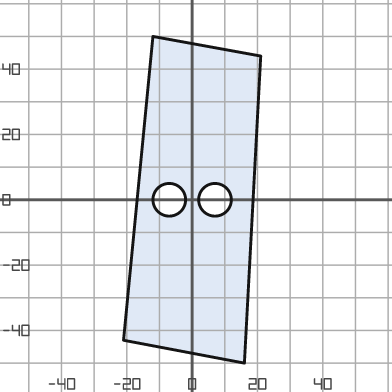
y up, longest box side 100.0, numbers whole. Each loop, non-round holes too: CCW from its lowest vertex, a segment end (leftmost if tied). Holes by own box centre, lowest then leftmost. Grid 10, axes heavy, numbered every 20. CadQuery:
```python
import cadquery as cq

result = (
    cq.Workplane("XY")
    .moveTo(16.0, -50.0)
    .lineTo(21.0, 44.0)
    .lineTo(-12.0, 50.0)
    .lineTo(-21.0, -43.0)
    .close()
    .moveTo(-7.0, 0.0)
    .circle(5.0)
    .moveTo(7.0, 0.0)
    .circle(5.0)
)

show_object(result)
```